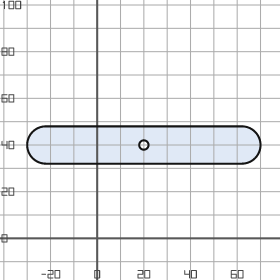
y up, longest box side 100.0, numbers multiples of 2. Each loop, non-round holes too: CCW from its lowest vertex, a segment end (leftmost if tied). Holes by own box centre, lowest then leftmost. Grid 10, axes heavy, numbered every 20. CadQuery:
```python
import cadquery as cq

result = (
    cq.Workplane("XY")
    .moveTo(-22.0, 32.0)
    .lineTo(62.0, 32.0)
    .threePointArc((70.0, 40.0), (62.0, 48.0))
    .lineTo(-22.0, 48.0)
    .threePointArc((-30.0, 40.0), (-22.0, 32.0))
    .close()
    .moveTo(20.0, 40.0)
    .circle(2.0)
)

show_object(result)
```